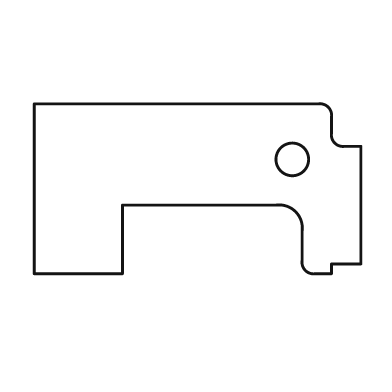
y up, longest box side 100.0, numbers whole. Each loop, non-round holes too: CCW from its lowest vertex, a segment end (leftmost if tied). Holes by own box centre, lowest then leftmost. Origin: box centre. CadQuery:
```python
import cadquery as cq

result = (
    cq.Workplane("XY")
    .moveTo(-50.0, -26.0)
    .lineTo(-23.0, -26.0)
    .lineTo(-23.0, -5.0)
    .lineTo(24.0, -5.0)
    .threePointArc((30.0, -7.0), (32.0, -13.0))
    .lineTo(32.0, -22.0)
    .threePointArc((33.0, -25.0), (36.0, -26.0))
    .lineTo(41.0, -26.0)
    .lineTo(41.0, -23.0)
    .lineTo(50.0, -23.0)
    .lineTo(50.0, 13.0)
    .lineTo(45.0, 13.0)
    .threePointArc((42.0, 14.0), (41.0, 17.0))
    .lineTo(41.0, 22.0)
    .threePointArc((40.0, 25.0), (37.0, 26.0))
    .lineTo(-50.0, 26.0)
    .close()
    .moveTo(29.0, 9.0)
    .circle(5.0)
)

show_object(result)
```